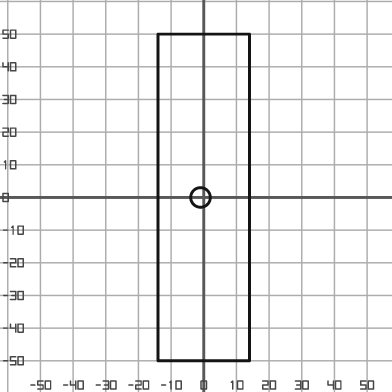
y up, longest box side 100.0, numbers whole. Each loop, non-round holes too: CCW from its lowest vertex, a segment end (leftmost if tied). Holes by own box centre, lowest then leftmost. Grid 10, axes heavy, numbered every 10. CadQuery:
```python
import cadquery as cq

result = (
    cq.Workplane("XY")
    .moveTo(-14.0, -50.0)
    .lineTo(14.0, -50.0)
    .lineTo(14.0, 50.0)
    .lineTo(-14.0, 50.0)
    .close()
    .moveTo(-1.0, 0.0)
    .circle(3.0)
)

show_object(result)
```